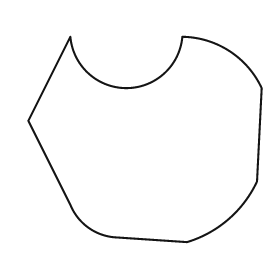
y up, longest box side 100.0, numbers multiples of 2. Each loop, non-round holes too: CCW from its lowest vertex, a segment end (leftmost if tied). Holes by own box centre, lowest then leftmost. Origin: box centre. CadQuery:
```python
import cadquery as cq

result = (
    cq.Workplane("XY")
    .moveTo(18.0, -44.0)
    .threePointArc((36.0, -34.0), (48.0, -18.0))
    .lineTo(50.0, 22.0)
    .threePointArc((36.0, 38.0), (16.0, 44.0))
    .threePointArc((-8.0, 22.0), (-32.0, 44.0))
    .lineTo(-50.0, 8.0)
    .lineTo(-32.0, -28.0)
    .threePointArc((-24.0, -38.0), (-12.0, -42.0))
    .close()
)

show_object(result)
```